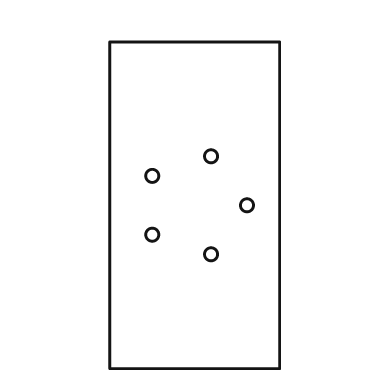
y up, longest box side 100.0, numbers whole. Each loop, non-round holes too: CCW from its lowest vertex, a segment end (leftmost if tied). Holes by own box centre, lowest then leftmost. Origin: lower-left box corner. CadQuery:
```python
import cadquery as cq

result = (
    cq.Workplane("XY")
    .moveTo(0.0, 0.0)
    .lineTo(52.0, 0.0)
    .lineTo(52.0, 100.0)
    .lineTo(0.0, 100.0)
    .close()
    .moveTo(31.0, 35.0)
    .circle(2.0)
    .moveTo(13.0, 41.0)
    .circle(2.0)
    .moveTo(42.0, 50.0)
    .circle(2.0)
    .moveTo(13.0, 59.0)
    .circle(2.0)
    .moveTo(31.0, 65.0)
    .circle(2.0)
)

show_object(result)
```